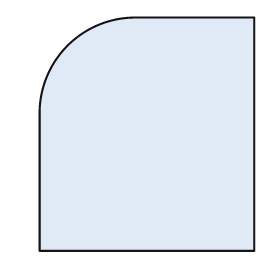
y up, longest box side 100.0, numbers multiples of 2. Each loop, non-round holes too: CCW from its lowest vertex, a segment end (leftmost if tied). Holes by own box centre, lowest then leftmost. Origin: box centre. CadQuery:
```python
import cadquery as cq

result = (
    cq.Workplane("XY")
    .moveTo(-46.0, -50.0)
    .lineTo(46.0, -50.0)
    .lineTo(46.0, 50.0)
    .lineTo(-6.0, 50.0)
    .threePointArc((-34.0, 38.0), (-46.0, 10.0))
    .close()
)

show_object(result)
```